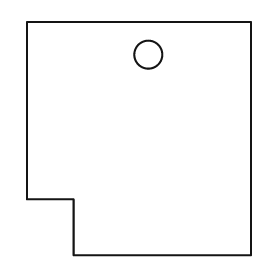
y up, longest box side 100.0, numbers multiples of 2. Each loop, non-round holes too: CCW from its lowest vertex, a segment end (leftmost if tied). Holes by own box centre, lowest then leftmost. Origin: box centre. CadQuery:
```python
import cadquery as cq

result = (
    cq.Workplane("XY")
    .moveTo(-28.0, -50.0)
    .lineTo(48.0, -50.0)
    .lineTo(48.0, 50.0)
    .lineTo(-48.0, 50.0)
    .lineTo(-48.0, -26.0)
    .lineTo(-28.0, -26.0)
    .close()
    .moveTo(4.0, 36.0)
    .circle(6.0)
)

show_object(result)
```